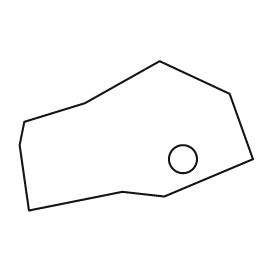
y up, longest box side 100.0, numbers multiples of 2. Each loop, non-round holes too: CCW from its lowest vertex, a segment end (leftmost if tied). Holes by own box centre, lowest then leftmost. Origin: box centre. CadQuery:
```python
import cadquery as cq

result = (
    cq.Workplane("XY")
    .moveTo(-46.0, -32.0)
    .lineTo(-6.0, -24.0)
    .lineTo(12.0, -26.0)
    .lineTo(50.0, -10.0)
    .lineTo(40.0, 18.0)
    .lineTo(10.0, 32.0)
    .lineTo(-22.0, 14.0)
    .lineTo(-48.0, 6.0)
    .lineTo(-50.0, -4.0)
    .close()
    .moveTo(20.0, -10.0)
    .circle(6.0)
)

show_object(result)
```